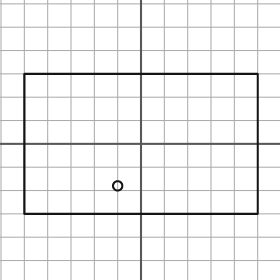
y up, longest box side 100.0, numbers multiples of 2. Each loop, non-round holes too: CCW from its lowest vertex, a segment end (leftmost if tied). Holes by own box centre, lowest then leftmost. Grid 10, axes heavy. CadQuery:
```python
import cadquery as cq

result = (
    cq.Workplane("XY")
    .moveTo(-50.0, -30.0)
    .lineTo(50.0, -30.0)
    .lineTo(50.0, 30.0)
    .lineTo(-50.0, 30.0)
    .close()
    .moveTo(-10.0, -18.0)
    .circle(2.0)
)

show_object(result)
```